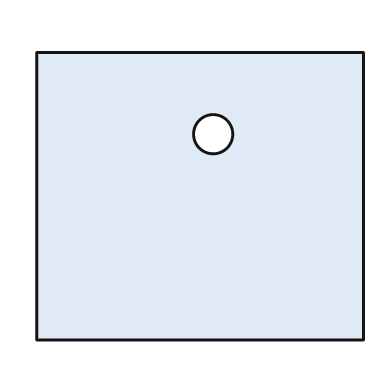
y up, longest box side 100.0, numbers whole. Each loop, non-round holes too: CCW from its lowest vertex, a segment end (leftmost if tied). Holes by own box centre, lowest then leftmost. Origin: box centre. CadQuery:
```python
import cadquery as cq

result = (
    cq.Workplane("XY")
    .moveTo(-50.0, -44.0)
    .lineTo(50.0, -44.0)
    .lineTo(50.0, 44.0)
    .lineTo(-50.0, 44.0)
    .close()
    .moveTo(4.0, 19.0)
    .circle(6.0)
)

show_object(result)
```